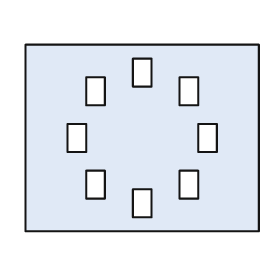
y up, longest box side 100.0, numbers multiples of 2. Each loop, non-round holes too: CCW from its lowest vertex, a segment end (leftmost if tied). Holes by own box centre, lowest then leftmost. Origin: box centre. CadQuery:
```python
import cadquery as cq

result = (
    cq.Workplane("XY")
    .moveTo(-50.0, -40.0)
    .lineTo(50.0, -40.0)
    .lineTo(50.0, 40.0)
    .lineTo(-50.0, 40.0)
    .close()
    .moveTo(-4.0, -34.0)
    .lineTo(4.0, -34.0)
    .lineTo(4.0, -22.0)
    .lineTo(-4.0, -22.0)
    .close()
    .moveTo(-24.0, -26.0)
    .lineTo(-16.0, -26.0)
    .lineTo(-16.0, -14.0)
    .lineTo(-24.0, -14.0)
    .close()
    .moveTo(16.0, -26.0)
    .lineTo(24.0, -26.0)
    .lineTo(24.0, -14.0)
    .lineTo(16.0, -14.0)
    .close()
    .moveTo(-32.0, -6.0)
    .lineTo(-24.0, -6.0)
    .lineTo(-24.0, 6.0)
    .lineTo(-32.0, 6.0)
    .close()
    .moveTo(24.0, -6.0)
    .lineTo(32.0, -6.0)
    .lineTo(32.0, 6.0)
    .lineTo(24.0, 6.0)
    .close()
    .moveTo(-24.0, 14.0)
    .lineTo(-16.0, 14.0)
    .lineTo(-16.0, 26.0)
    .lineTo(-24.0, 26.0)
    .close()
    .moveTo(16.0, 14.0)
    .lineTo(24.0, 14.0)
    .lineTo(24.0, 26.0)
    .lineTo(16.0, 26.0)
    .close()
    .moveTo(-4.0, 22.0)
    .lineTo(4.0, 22.0)
    .lineTo(4.0, 34.0)
    .lineTo(-4.0, 34.0)
    .close()
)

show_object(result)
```